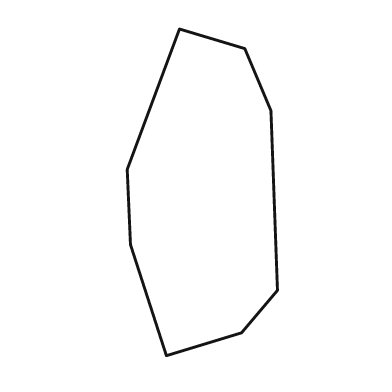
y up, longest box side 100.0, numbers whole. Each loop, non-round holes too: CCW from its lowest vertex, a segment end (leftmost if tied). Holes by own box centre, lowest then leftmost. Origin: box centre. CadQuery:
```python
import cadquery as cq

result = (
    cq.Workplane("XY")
    .moveTo(-11.0, -50.0)
    .lineTo(12.0, -43.0)
    .lineTo(23.0, -30.0)
    .lineTo(21.0, 25.0)
    .lineTo(13.0, 44.0)
    .lineTo(-7.0, 50.0)
    .lineTo(-23.0, 7.0)
    .lineTo(-22.0, -16.0)
    .close()
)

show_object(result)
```